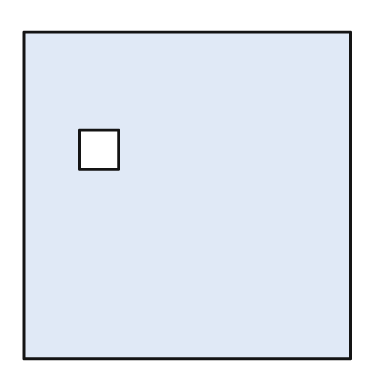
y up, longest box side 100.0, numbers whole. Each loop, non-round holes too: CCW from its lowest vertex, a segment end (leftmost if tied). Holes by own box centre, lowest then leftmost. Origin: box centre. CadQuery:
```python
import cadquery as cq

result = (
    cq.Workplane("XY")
    .moveTo(-50.0, -50.0)
    .lineTo(50.0, -50.0)
    .lineTo(50.0, 50.0)
    .lineTo(-50.0, 50.0)
    .close()
    .moveTo(-33.0, 8.0)
    .lineTo(-21.0, 8.0)
    .lineTo(-21.0, 20.0)
    .lineTo(-33.0, 20.0)
    .close()
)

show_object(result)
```